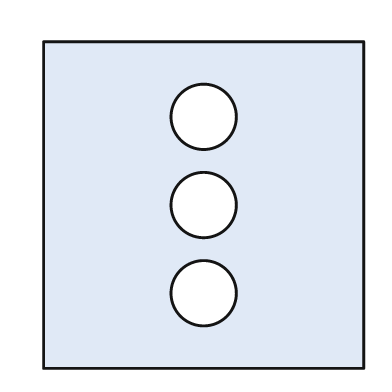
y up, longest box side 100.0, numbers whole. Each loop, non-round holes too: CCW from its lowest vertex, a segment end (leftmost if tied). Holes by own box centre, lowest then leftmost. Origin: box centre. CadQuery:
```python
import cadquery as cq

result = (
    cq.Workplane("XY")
    .moveTo(-49.0, -50.0)
    .lineTo(49.0, -50.0)
    .lineTo(49.0, 50.0)
    .lineTo(-49.0, 50.0)
    .close()
    .moveTo(0.0, -27.0)
    .circle(10.0)
    .moveTo(0.0, 0.0)
    .circle(10.0)
    .moveTo(0.0, 27.0)
    .circle(10.0)
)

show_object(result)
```